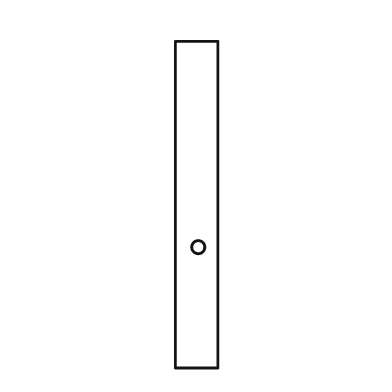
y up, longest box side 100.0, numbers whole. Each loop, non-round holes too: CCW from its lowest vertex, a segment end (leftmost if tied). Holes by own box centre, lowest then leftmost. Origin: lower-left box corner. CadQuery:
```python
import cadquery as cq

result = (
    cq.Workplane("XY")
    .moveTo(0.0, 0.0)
    .lineTo(13.0, 0.0)
    .lineTo(13.0, 100.0)
    .lineTo(0.0, 100.0)
    .close()
    .moveTo(7.0, 37.0)
    .circle(2.0)
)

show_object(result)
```